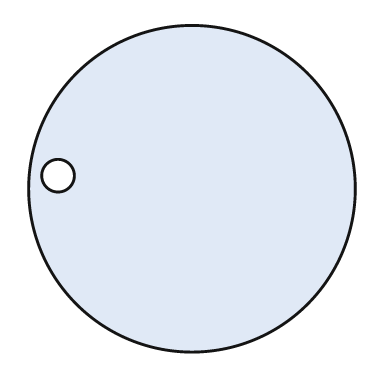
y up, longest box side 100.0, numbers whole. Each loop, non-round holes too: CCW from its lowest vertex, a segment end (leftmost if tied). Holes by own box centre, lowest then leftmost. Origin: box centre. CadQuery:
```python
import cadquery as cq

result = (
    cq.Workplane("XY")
    .moveTo(0.0, 0.0)
    .circle(50.0)
    .moveTo(-41.0, 4.0)
    .circle(5.0)
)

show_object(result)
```